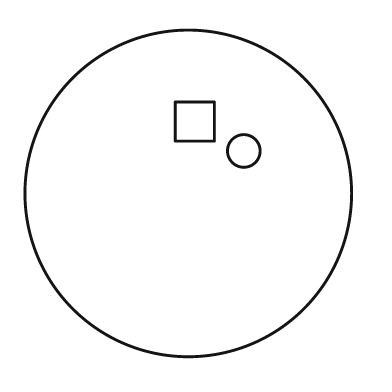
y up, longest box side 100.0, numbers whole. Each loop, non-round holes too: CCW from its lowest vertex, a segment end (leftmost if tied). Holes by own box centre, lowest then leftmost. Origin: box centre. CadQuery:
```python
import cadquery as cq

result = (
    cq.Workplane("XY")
    .moveTo(0.0, 0.0)
    .circle(50.0)
    .moveTo(17.0, 13.0)
    .circle(5.0)
    .moveTo(-4.0, 16.0)
    .lineTo(8.0, 16.0)
    .lineTo(8.0, 28.0)
    .lineTo(-4.0, 28.0)
    .close()
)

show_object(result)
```